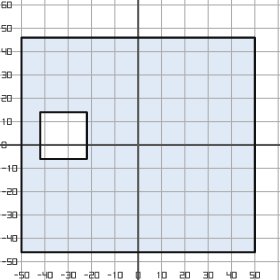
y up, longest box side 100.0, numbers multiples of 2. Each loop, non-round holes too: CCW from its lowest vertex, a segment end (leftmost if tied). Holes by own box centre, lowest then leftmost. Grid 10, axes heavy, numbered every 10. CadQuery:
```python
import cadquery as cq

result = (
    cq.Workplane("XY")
    .moveTo(-50.0, -46.0)
    .lineTo(50.0, -46.0)
    .lineTo(50.0, 46.0)
    .lineTo(-50.0, 46.0)
    .close()
    .moveTo(-42.0, -6.0)
    .lineTo(-22.0, -6.0)
    .lineTo(-22.0, 14.0)
    .lineTo(-42.0, 14.0)
    .close()
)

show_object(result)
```